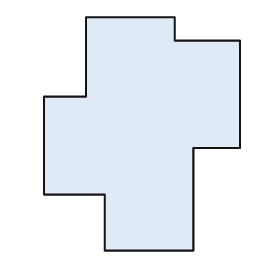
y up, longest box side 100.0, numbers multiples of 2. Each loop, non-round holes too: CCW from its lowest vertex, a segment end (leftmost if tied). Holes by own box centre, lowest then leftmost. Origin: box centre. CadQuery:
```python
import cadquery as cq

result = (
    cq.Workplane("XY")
    .moveTo(-16.0, -50.0)
    .lineTo(22.0, -50.0)
    .lineTo(22.0, -6.0)
    .lineTo(42.0, -6.0)
    .lineTo(42.0, 40.0)
    .lineTo(14.0, 40.0)
    .lineTo(14.0, 50.0)
    .lineTo(-24.0, 50.0)
    .lineTo(-24.0, 16.0)
    .lineTo(-42.0, 16.0)
    .lineTo(-42.0, -26.0)
    .lineTo(-16.0, -26.0)
    .close()
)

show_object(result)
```